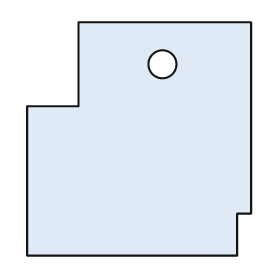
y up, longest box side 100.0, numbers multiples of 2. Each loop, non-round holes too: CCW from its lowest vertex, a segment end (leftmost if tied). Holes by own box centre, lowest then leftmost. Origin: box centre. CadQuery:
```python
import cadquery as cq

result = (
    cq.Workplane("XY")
    .moveTo(-48.0, -50.0)
    .lineTo(42.0, -50.0)
    .lineTo(42.0, -32.0)
    .lineTo(48.0, -32.0)
    .lineTo(48.0, 50.0)
    .lineTo(-26.0, 50.0)
    .lineTo(-26.0, 14.0)
    .lineTo(-48.0, 14.0)
    .close()
    .moveTo(10.0, 32.0)
    .circle(6.0)
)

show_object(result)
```